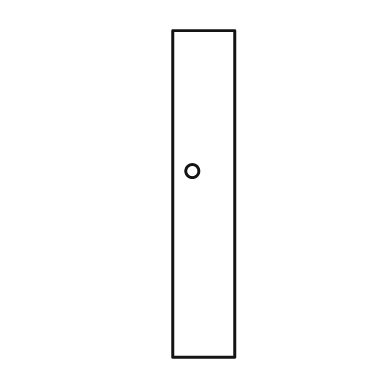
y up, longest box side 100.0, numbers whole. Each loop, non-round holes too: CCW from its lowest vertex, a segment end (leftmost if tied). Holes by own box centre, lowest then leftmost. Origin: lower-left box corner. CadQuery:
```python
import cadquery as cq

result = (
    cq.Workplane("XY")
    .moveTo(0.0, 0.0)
    .lineTo(19.0, 0.0)
    .lineTo(19.0, 100.0)
    .lineTo(0.0, 100.0)
    .close()
    .moveTo(6.0, 57.0)
    .circle(2.0)
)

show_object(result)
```